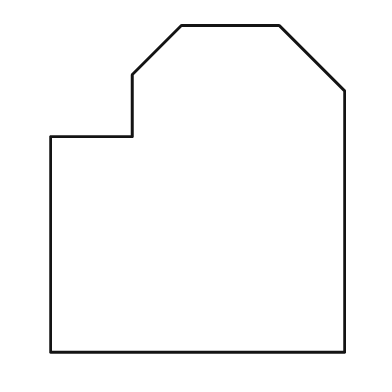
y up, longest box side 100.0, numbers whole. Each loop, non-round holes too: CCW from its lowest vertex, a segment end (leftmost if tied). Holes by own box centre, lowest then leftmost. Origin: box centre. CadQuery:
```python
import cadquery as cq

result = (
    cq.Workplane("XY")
    .moveTo(-45.0, -50.0)
    .lineTo(45.0, -50.0)
    .lineTo(45.0, 30.0)
    .lineTo(25.0, 50.0)
    .lineTo(-5.0, 50.0)
    .lineTo(-20.0, 35.0)
    .lineTo(-20.0, 16.0)
    .lineTo(-45.0, 16.0)
    .close()
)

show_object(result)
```